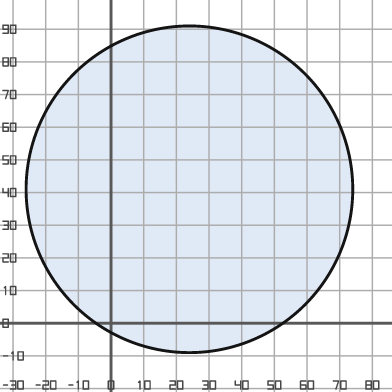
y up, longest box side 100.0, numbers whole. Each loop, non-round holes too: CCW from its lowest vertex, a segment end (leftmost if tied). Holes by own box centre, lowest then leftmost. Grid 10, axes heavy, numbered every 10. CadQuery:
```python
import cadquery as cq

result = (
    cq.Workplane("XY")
    .moveTo(24.0, 41.0)
    .circle(50.0)
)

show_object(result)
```